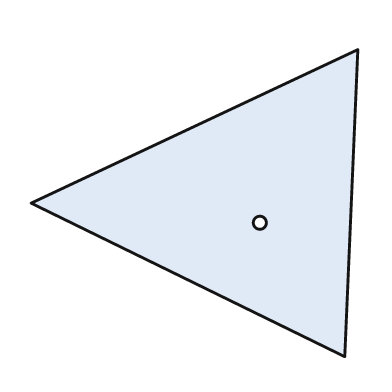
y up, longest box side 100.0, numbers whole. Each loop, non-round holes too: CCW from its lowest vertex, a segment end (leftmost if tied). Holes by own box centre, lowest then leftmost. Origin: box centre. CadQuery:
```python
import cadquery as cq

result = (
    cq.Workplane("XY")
    .moveTo(46.0, -47.0)
    .lineTo(50.0, 47.0)
    .lineTo(-50.0, 0.0)
    .close()
    .moveTo(20.0, -6.0)
    .circle(2.0)
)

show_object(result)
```